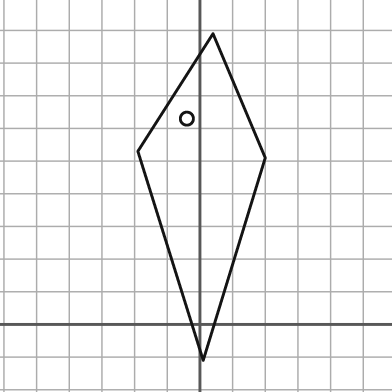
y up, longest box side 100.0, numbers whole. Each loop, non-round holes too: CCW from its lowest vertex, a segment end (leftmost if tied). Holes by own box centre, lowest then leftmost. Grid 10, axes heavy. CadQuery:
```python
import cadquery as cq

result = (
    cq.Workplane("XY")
    .moveTo(1.0, -11.0)
    .lineTo(20.0, 51.0)
    .lineTo(4.0, 89.0)
    .lineTo(-19.0, 53.0)
    .close()
    .moveTo(-4.0, 63.0)
    .circle(2.0)
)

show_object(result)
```